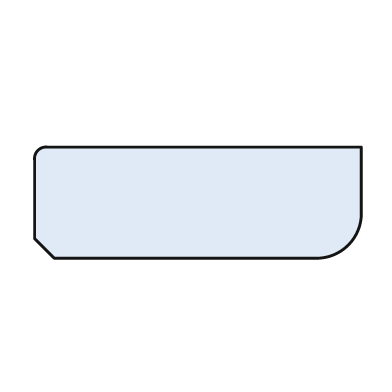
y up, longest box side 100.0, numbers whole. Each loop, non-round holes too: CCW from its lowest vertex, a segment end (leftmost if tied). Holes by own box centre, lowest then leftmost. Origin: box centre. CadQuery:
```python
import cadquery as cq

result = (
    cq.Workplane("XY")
    .moveTo(-44.0, -17.0)
    .lineTo(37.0, -17.0)
    .threePointArc((46.0, -13.0), (50.0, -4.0))
    .lineTo(50.0, 17.0)
    .lineTo(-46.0, 17.0)
    .threePointArc((-49.0, 16.0), (-50.0, 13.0))
    .lineTo(-50.0, -11.0)
    .close()
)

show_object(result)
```